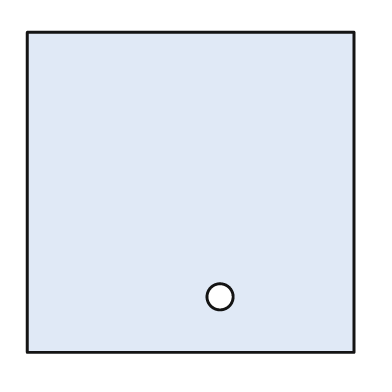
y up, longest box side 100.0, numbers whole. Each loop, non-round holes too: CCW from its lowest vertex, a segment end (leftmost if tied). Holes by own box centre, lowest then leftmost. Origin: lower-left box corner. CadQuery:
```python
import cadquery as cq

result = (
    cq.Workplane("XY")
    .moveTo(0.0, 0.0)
    .lineTo(100.0, 0.0)
    .lineTo(100.0, 98.0)
    .lineTo(0.0, 98.0)
    .close()
    .moveTo(59.0, 17.0)
    .circle(4.0)
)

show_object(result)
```